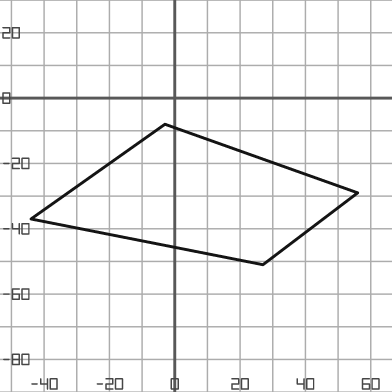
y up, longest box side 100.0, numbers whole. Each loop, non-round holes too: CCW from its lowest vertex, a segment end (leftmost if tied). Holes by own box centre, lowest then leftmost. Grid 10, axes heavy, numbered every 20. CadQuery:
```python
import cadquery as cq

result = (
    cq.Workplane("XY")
    .moveTo(27.0, -51.0)
    .lineTo(56.0, -29.0)
    .lineTo(-3.0, -8.0)
    .lineTo(-44.0, -37.0)
    .close()
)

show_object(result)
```